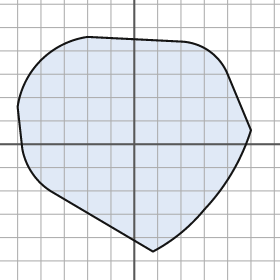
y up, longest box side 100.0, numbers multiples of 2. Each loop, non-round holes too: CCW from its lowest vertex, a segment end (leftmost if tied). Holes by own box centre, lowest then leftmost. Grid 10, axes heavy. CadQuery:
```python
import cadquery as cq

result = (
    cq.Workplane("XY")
    .moveTo(8.0, -46.0)
    .threePointArc((20.0, -38.0), (30.0, -28.0))
    .threePointArc((42.0, -12.0), (50.0, 6.0))
    .lineTo(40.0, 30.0)
    .threePointArc((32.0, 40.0), (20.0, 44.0))
    .lineTo(-20.0, 46.0)
    .threePointArc((-40.0, 36.0), (-50.0, 16.0))
    .lineTo(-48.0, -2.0)
    .threePointArc((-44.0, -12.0), (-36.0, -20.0))
    .close()
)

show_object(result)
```